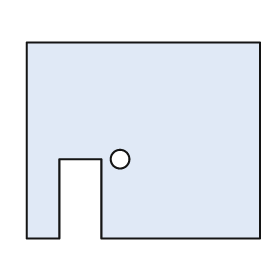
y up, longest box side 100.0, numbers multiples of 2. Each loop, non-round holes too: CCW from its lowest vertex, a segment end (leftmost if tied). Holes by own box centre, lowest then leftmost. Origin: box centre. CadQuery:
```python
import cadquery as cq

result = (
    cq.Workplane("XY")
    .moveTo(-50.0, -42.0)
    .lineTo(-36.0, -42.0)
    .lineTo(-36.0, -8.0)
    .lineTo(-18.0, -8.0)
    .lineTo(-18.0, -42.0)
    .lineTo(50.0, -42.0)
    .lineTo(50.0, 42.0)
    .lineTo(-50.0, 42.0)
    .close()
    .moveTo(-10.0, -8.0)
    .circle(4.0)
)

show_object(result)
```